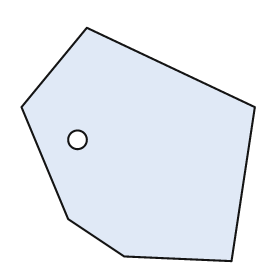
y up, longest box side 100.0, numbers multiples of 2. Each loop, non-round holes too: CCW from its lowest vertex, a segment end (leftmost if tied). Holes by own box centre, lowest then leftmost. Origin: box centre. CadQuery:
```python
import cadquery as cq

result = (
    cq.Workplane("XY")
    .moveTo(40.0, -50.0)
    .lineTo(50.0, 16.0)
    .lineTo(-22.0, 50.0)
    .lineTo(-50.0, 16.0)
    .lineTo(-30.0, -32.0)
    .lineTo(-6.0, -48.0)
    .close()
    .moveTo(-26.0, 2.0)
    .circle(4.0)
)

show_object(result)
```